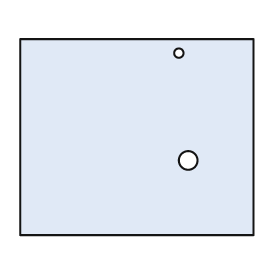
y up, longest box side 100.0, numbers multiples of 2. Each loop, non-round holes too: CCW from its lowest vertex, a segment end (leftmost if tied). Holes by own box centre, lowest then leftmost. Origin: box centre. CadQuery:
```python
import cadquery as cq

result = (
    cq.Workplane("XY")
    .moveTo(-50.0, -42.0)
    .lineTo(50.0, -42.0)
    .lineTo(50.0, 42.0)
    .lineTo(-50.0, 42.0)
    .close()
    .moveTo(22.0, -10.0)
    .circle(4.0)
    .moveTo(18.0, 36.0)
    .circle(2.0)
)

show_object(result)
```